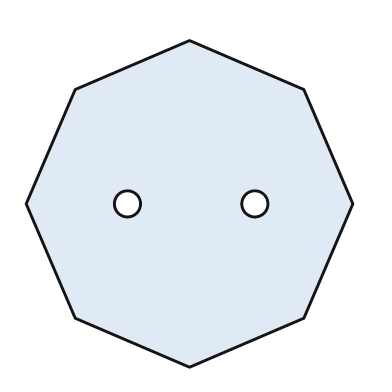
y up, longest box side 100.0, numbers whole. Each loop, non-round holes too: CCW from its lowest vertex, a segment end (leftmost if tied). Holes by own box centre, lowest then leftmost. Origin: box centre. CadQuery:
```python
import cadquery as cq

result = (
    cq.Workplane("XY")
    .moveTo(0.0, -50.0)
    .lineTo(35.0, -35.0)
    .lineTo(50.0, 0.0)
    .lineTo(35.0, 35.0)
    .lineTo(0.0, 50.0)
    .lineTo(-35.0, 35.0)
    .lineTo(-50.0, 0.0)
    .lineTo(-35.0, -35.0)
    .close()
    .moveTo(-19.0, 0.0)
    .circle(4.0)
    .moveTo(20.0, 0.0)
    .circle(4.0)
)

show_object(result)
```